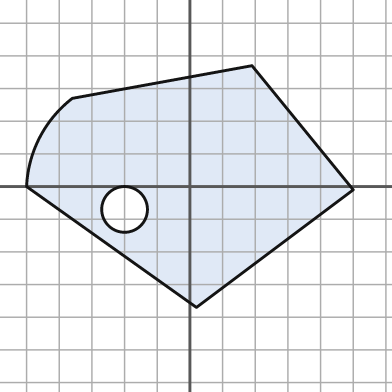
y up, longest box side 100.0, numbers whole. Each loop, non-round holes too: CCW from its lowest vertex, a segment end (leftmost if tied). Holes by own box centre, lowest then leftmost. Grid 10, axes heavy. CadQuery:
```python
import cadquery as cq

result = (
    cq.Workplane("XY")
    .moveTo(2.0, -37.0)
    .lineTo(50.0, -1.0)
    .lineTo(19.0, 37.0)
    .lineTo(-36.0, 27.0)
    .threePointArc((-46.0, 15.0), (-50.0, 0.0))
    .close()
    .moveTo(-20.0, -7.0)
    .circle(7.0)
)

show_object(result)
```